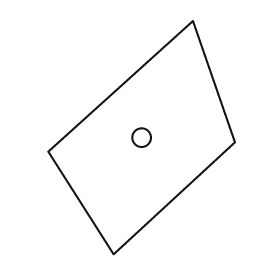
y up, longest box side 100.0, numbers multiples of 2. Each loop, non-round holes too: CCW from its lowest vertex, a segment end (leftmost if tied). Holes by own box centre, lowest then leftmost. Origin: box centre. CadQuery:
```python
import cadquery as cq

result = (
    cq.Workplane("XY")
    .moveTo(-12.0, -50.0)
    .lineTo(40.0, -2.0)
    .lineTo(22.0, 50.0)
    .lineTo(-40.0, -6.0)
    .close()
    .moveTo(0.0, 0.0)
    .circle(4.0)
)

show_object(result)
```